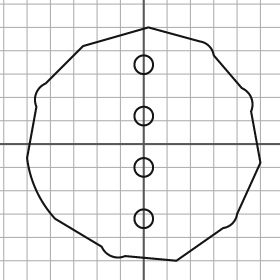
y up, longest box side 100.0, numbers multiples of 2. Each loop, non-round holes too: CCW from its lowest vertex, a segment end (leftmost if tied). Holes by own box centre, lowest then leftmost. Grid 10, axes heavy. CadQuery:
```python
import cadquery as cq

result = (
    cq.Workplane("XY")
    .moveTo(14.0, -50.0)
    .lineTo(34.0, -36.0)
    .threePointArc((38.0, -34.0), (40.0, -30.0))
    .lineTo(50.0, -8.0)
    .lineTo(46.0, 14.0)
    .threePointArc((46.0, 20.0), (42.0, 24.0))
    .lineTo(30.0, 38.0)
    .threePointArc((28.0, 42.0), (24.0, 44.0))
    .lineTo(2.0, 50.0)
    .lineTo(-26.0, 42.0)
    .lineTo(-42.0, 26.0)
    .threePointArc((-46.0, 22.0), (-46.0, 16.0))
    .lineTo(-50.0, -6.0)
    .threePointArc((-46.0, -20.0), (-38.0, -32.0))
    .lineTo(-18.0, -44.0)
    .threePointArc((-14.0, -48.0), (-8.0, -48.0))
    .close()
    .moveTo(0.0, -32.0)
    .circle(4.0)
    .moveTo(0.0, -10.0)
    .circle(4.0)
    .moveTo(0.0, 12.0)
    .circle(4.0)
    .moveTo(0.0, 34.0)
    .circle(4.0)
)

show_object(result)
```